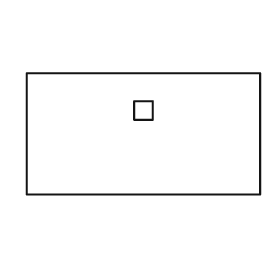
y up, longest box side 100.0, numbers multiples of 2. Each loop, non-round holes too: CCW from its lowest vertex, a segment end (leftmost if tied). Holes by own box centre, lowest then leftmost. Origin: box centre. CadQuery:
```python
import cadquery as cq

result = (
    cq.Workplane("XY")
    .moveTo(-50.0, -26.0)
    .lineTo(50.0, -26.0)
    .lineTo(50.0, 26.0)
    .lineTo(-50.0, 26.0)
    .close()
    .moveTo(-4.0, 6.0)
    .lineTo(4.0, 6.0)
    .lineTo(4.0, 14.0)
    .lineTo(-4.0, 14.0)
    .close()
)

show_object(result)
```